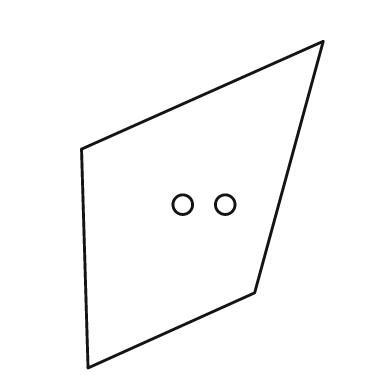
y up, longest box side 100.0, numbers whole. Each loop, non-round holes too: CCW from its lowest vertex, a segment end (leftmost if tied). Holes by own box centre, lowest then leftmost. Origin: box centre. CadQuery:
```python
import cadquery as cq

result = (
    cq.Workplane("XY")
    .moveTo(-35.0, -50.0)
    .lineTo(16.0, -27.0)
    .lineTo(37.0, 50.0)
    .lineTo(-37.0, 17.0)
    .close()
    .moveTo(-6.0, 0.0)
    .circle(3.0)
    .moveTo(7.0, 0.0)
    .circle(3.0)
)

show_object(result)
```